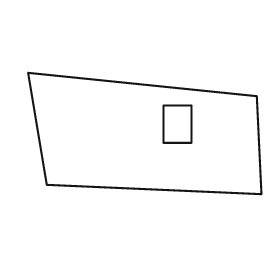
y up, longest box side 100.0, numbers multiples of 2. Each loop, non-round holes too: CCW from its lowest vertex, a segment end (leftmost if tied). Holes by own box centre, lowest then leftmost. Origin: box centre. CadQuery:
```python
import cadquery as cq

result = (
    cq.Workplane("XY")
    .moveTo(50.0, -26.0)
    .lineTo(48.0, 16.0)
    .lineTo(-50.0, 26.0)
    .lineTo(-42.0, -22.0)
    .close()
    .moveTo(8.0, -4.0)
    .lineTo(20.0, -4.0)
    .lineTo(20.0, 12.0)
    .lineTo(8.0, 12.0)
    .close()
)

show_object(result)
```